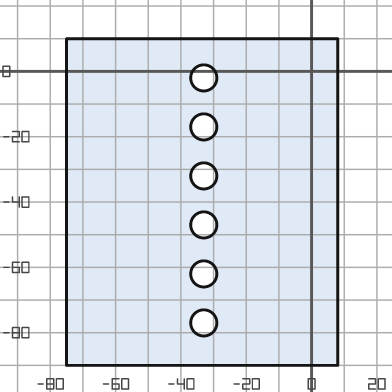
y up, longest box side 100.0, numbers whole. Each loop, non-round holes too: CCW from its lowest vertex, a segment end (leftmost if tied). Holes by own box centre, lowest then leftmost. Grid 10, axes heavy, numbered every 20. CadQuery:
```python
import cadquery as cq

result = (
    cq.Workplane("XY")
    .moveTo(-75.0, -90.0)
    .lineTo(8.0, -90.0)
    .lineTo(8.0, 10.0)
    .lineTo(-75.0, 10.0)
    .close()
    .moveTo(-33.0, -77.0)
    .circle(4.0)
    .moveTo(-33.0, -62.0)
    .circle(4.0)
    .moveTo(-33.0, -47.0)
    .circle(4.0)
    .moveTo(-33.0, -32.0)
    .circle(4.0)
    .moveTo(-33.0, -17.0)
    .circle(4.0)
    .moveTo(-33.0, -2.0)
    .circle(4.0)
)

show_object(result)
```